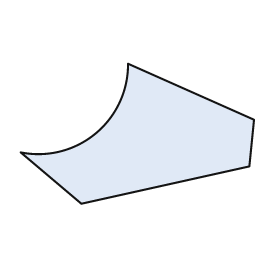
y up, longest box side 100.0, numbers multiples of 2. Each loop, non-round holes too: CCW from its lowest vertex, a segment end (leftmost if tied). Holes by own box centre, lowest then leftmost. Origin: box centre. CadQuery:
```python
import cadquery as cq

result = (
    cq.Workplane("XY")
    .moveTo(-24.0, -30.0)
    .lineTo(48.0, -14.0)
    .lineTo(50.0, 6.0)
    .lineTo(-4.0, 30.0)
    .threePointArc((-18.0, 0.0), (-50.0, -8.0))
    .close()
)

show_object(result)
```